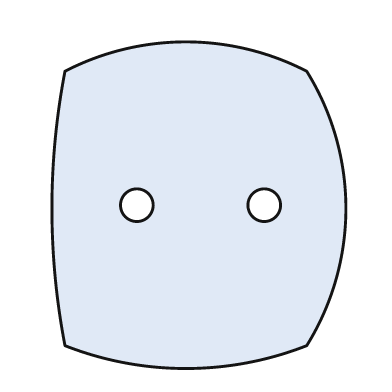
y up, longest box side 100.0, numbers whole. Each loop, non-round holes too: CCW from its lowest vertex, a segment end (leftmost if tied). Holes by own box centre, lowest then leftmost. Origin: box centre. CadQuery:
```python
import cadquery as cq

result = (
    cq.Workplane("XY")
    .moveTo(-41.0, -43.0)
    .threePointArc((-4.0, -50.0), (33.0, -43.0))
    .threePointArc((45.0, -1.0), (33.0, 41.0))
    .threePointArc((-4.0, 50.0), (-41.0, 41.0))
    .threePointArc((-45.0, -1.0), (-41.0, -43.0))
    .close()
    .moveTo(-19.0, 0.0)
    .circle(5.0)
    .moveTo(20.0, 0.0)
    .circle(5.0)
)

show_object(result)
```